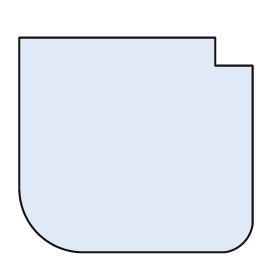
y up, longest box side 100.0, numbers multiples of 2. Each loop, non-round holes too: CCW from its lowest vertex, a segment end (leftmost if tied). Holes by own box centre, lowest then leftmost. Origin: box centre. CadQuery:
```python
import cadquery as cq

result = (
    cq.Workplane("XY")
    .moveTo(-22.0, -46.0)
    .lineTo(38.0, -46.0)
    .threePointArc((46.0, -42.0), (50.0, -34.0))
    .lineTo(50.0, 34.0)
    .lineTo(34.0, 34.0)
    .lineTo(34.0, 46.0)
    .lineTo(-50.0, 46.0)
    .lineTo(-50.0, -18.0)
    .threePointArc((-42.0, -38.0), (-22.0, -46.0))
    .close()
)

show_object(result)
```